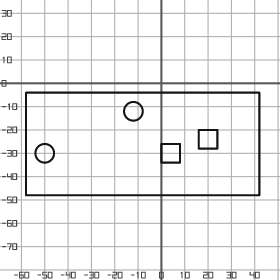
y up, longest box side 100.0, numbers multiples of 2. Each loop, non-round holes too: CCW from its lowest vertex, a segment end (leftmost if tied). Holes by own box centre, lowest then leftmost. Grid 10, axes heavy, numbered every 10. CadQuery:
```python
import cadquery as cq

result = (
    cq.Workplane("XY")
    .moveTo(-58.0, -48.0)
    .lineTo(42.0, -48.0)
    .lineTo(42.0, -4.0)
    .lineTo(-58.0, -4.0)
    .close()
    .moveTo(-50.0, -30.0)
    .circle(4.0)
    .moveTo(0.0, -34.0)
    .lineTo(8.0, -34.0)
    .lineTo(8.0, -26.0)
    .lineTo(0.0, -26.0)
    .close()
    .moveTo(16.0, -28.0)
    .lineTo(24.0, -28.0)
    .lineTo(24.0, -20.0)
    .lineTo(16.0, -20.0)
    .close()
    .moveTo(-12.0, -12.0)
    .circle(4.0)
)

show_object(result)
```